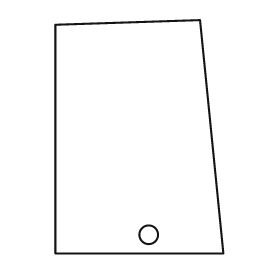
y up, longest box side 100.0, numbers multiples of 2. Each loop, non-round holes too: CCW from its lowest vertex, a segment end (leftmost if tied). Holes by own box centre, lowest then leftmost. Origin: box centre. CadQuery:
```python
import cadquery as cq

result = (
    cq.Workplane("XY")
    .moveTo(-36.0, -50.0)
    .lineTo(36.0, -50.0)
    .lineTo(26.0, 50.0)
    .lineTo(-36.0, 48.0)
    .close()
    .moveTo(4.0, -42.0)
    .circle(4.0)
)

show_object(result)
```